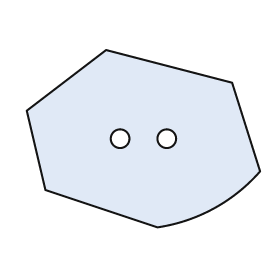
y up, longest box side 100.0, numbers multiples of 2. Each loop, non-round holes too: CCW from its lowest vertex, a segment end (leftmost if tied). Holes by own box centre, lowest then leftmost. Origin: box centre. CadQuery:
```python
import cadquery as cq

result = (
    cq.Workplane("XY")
    .moveTo(6.0, -38.0)
    .threePointArc((30.0, -30.0), (50.0, -14.0))
    .lineTo(38.0, 24.0)
    .lineTo(-16.0, 38.0)
    .lineTo(-50.0, 12.0)
    .lineTo(-42.0, -22.0)
    .close()
    .moveTo(-10.0, 0.0)
    .circle(4.0)
    .moveTo(10.0, 0.0)
    .circle(4.0)
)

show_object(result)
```